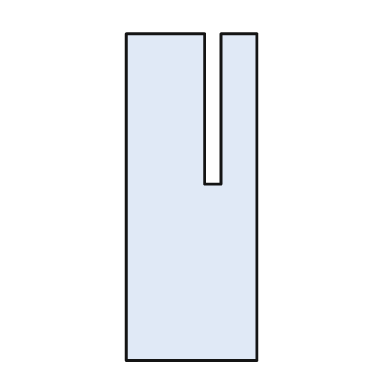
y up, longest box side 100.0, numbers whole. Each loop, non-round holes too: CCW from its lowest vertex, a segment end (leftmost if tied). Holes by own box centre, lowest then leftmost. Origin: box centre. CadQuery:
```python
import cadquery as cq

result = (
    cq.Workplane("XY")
    .moveTo(-20.0, -50.0)
    .lineTo(20.0, -50.0)
    .lineTo(20.0, 50.0)
    .lineTo(9.0, 50.0)
    .lineTo(9.0, 4.0)
    .lineTo(4.0, 4.0)
    .lineTo(4.0, 50.0)
    .lineTo(-20.0, 50.0)
    .close()
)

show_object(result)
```